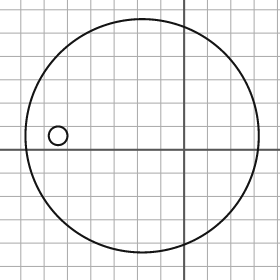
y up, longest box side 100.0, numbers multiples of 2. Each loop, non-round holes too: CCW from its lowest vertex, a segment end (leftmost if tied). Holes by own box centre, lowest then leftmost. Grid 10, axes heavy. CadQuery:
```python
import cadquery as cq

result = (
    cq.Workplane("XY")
    .moveTo(-18.0, 6.0)
    .circle(50.0)
    .moveTo(-54.0, 6.0)
    .circle(4.0)
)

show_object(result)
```